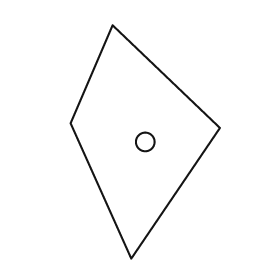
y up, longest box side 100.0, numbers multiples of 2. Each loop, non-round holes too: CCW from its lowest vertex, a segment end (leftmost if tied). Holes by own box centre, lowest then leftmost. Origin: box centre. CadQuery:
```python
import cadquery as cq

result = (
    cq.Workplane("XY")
    .moveTo(-6.0, -50.0)
    .lineTo(32.0, 6.0)
    .lineTo(-14.0, 50.0)
    .lineTo(-32.0, 8.0)
    .close()
    .moveTo(0.0, 0.0)
    .circle(4.0)
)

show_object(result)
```